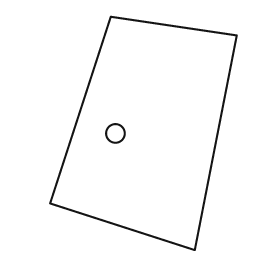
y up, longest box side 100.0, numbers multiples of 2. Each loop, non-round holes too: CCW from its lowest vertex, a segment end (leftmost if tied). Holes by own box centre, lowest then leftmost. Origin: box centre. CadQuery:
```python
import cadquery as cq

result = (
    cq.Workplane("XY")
    .moveTo(22.0, -50.0)
    .lineTo(40.0, 42.0)
    .lineTo(-14.0, 50.0)
    .lineTo(-40.0, -30.0)
    .close()
    .moveTo(-12.0, 0.0)
    .circle(4.0)
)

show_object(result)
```